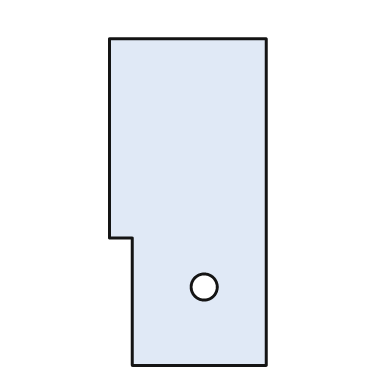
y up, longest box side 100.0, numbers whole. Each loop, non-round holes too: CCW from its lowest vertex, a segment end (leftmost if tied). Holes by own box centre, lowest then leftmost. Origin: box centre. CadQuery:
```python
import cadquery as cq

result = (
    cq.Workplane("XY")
    .moveTo(-17.0, -50.0)
    .lineTo(24.0, -50.0)
    .lineTo(24.0, 50.0)
    .lineTo(-24.0, 50.0)
    .lineTo(-24.0, -11.0)
    .lineTo(-17.0, -11.0)
    .close()
    .moveTo(5.0, -26.0)
    .circle(4.0)
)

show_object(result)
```